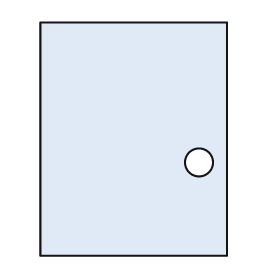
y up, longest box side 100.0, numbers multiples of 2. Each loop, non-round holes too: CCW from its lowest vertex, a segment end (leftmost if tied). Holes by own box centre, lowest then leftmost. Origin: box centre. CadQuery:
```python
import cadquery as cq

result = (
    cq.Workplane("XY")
    .moveTo(-40.0, -50.0)
    .lineTo(40.0, -50.0)
    .lineTo(40.0, 50.0)
    .lineTo(-40.0, 50.0)
    .close()
    .moveTo(28.0, -10.0)
    .circle(6.0)
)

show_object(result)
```